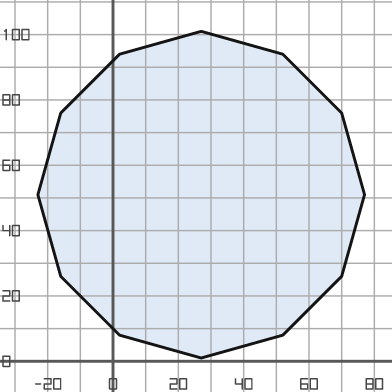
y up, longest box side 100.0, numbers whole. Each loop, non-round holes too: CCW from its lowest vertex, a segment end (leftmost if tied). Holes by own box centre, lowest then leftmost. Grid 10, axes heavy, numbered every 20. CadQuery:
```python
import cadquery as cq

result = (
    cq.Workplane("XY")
    .moveTo(27.0, 1.0)
    .lineTo(52.0, 8.0)
    .lineTo(70.0, 26.0)
    .lineTo(77.0, 51.0)
    .lineTo(70.0, 76.0)
    .lineTo(52.0, 94.0)
    .lineTo(27.0, 101.0)
    .lineTo(2.0, 94.0)
    .lineTo(-16.0, 76.0)
    .lineTo(-23.0, 51.0)
    .lineTo(-16.0, 26.0)
    .lineTo(2.0, 8.0)
    .close()
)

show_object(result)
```